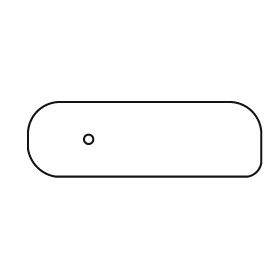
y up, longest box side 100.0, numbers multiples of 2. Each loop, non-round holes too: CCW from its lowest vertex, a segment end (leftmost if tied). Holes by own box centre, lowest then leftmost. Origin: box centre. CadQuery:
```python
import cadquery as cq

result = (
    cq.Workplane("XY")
    .moveTo(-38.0, -16.0)
    .lineTo(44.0, -16.0)
    .threePointArc((48.0, -14.0), (50.0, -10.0))
    .lineTo(50.0, 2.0)
    .threePointArc((46.0, 12.0), (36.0, 16.0))
    .lineTo(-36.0, 16.0)
    .threePointArc((-46.0, 12.0), (-50.0, 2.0))
    .lineTo(-50.0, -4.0)
    .threePointArc((-46.0, -12.0), (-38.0, -16.0))
    .close()
    .moveTo(-24.0, 0.0)
    .circle(2.0)
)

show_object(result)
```